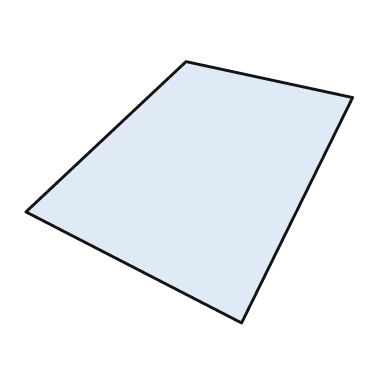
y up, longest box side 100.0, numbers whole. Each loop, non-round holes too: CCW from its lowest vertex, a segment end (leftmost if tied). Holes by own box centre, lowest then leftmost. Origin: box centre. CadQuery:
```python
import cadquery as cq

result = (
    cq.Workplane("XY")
    .moveTo(16.0, -40.0)
    .lineTo(50.0, 29.0)
    .lineTo(-1.0, 40.0)
    .lineTo(-50.0, -6.0)
    .close()
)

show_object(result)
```